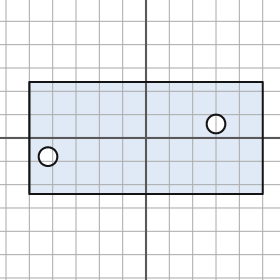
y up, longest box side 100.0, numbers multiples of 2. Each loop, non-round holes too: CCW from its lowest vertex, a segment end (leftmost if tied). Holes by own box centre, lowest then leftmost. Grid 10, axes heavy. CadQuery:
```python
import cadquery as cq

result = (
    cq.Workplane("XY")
    .moveTo(-50.0, -24.0)
    .lineTo(50.0, -24.0)
    .lineTo(50.0, 24.0)
    .lineTo(-50.0, 24.0)
    .close()
    .moveTo(-42.0, -8.0)
    .circle(4.0)
    .moveTo(30.0, 6.0)
    .circle(4.0)
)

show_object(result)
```